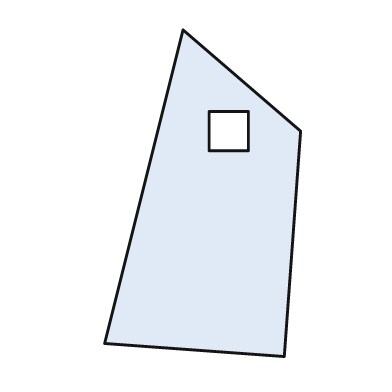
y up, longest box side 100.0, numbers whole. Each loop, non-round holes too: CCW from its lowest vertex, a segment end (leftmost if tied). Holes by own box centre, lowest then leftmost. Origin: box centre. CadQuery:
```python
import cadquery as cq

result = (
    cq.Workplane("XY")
    .moveTo(25.0, -50.0)
    .lineTo(30.0, 19.0)
    .lineTo(-6.0, 50.0)
    .lineTo(-30.0, -46.0)
    .close()
    .moveTo(2.0, 13.0)
    .lineTo(14.0, 13.0)
    .lineTo(14.0, 25.0)
    .lineTo(2.0, 25.0)
    .close()
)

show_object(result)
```